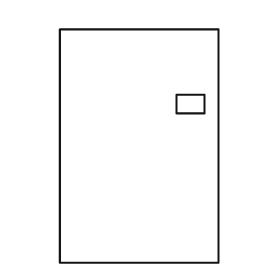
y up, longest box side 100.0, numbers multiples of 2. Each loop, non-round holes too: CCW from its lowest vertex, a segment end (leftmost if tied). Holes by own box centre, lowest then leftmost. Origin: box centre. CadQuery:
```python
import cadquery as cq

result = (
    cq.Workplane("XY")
    .moveTo(-34.0, -50.0)
    .lineTo(34.0, -50.0)
    .lineTo(34.0, 50.0)
    .lineTo(-34.0, 50.0)
    .close()
    .moveTo(16.0, 14.0)
    .lineTo(28.0, 14.0)
    .lineTo(28.0, 22.0)
    .lineTo(16.0, 22.0)
    .close()
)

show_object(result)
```